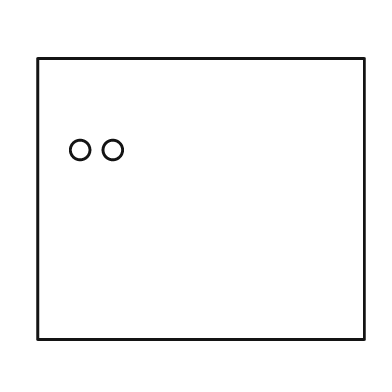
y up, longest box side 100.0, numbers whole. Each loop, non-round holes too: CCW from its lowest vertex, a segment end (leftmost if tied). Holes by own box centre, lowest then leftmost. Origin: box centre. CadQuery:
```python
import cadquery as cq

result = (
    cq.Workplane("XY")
    .moveTo(-50.0, -43.0)
    .lineTo(50.0, -43.0)
    .lineTo(50.0, 43.0)
    .lineTo(-50.0, 43.0)
    .close()
    .moveTo(-37.0, 15.0)
    .circle(3.0)
    .moveTo(-27.0, 15.0)
    .circle(3.0)
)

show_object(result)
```